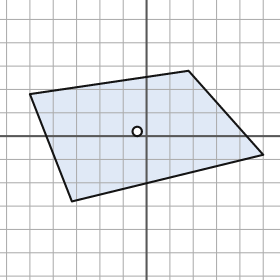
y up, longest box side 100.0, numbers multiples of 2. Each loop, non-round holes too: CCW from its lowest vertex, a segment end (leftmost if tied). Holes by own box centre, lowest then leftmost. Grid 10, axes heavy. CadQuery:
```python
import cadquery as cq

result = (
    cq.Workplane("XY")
    .moveTo(-32.0, -28.0)
    .lineTo(50.0, -8.0)
    .lineTo(18.0, 28.0)
    .lineTo(-50.0, 18.0)
    .close()
    .moveTo(-4.0, 2.0)
    .circle(2.0)
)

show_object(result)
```